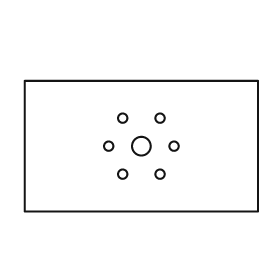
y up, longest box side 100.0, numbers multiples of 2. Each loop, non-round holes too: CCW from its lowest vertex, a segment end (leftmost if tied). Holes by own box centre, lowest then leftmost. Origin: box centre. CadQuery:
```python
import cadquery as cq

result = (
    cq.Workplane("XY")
    .moveTo(-50.0, -28.0)
    .lineTo(50.0, -28.0)
    .lineTo(50.0, 28.0)
    .lineTo(-50.0, 28.0)
    .close()
    .moveTo(-8.0, -12.0)
    .circle(2.0)
    .moveTo(8.0, -12.0)
    .circle(2.0)
    .moveTo(-14.0, 0.0)
    .circle(2.0)
    .moveTo(0.0, 0.0)
    .circle(4.0)
    .moveTo(14.0, 0.0)
    .circle(2.0)
    .moveTo(-8.0, 12.0)
    .circle(2.0)
    .moveTo(8.0, 12.0)
    .circle(2.0)
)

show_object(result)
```